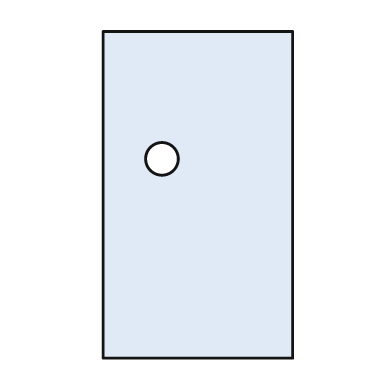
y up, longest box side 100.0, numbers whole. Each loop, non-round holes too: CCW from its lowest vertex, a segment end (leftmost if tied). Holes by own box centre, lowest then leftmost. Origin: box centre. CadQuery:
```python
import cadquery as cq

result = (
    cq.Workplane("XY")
    .moveTo(-29.0, -50.0)
    .lineTo(29.0, -50.0)
    .lineTo(29.0, 50.0)
    .lineTo(-29.0, 50.0)
    .close()
    .moveTo(-11.0, 11.0)
    .circle(5.0)
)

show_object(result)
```